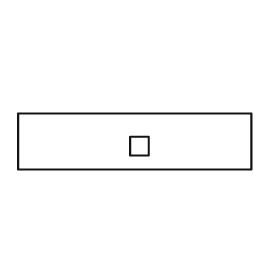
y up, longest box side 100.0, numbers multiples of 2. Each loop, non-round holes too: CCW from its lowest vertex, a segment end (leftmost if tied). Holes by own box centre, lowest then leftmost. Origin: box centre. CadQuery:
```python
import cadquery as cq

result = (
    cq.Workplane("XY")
    .moveTo(-50.0, -12.0)
    .lineTo(50.0, -12.0)
    .lineTo(50.0, 12.0)
    .lineTo(-50.0, 12.0)
    .close()
    .moveTo(-2.0, -6.0)
    .lineTo(6.0, -6.0)
    .lineTo(6.0, 2.0)
    .lineTo(-2.0, 2.0)
    .close()
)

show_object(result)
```